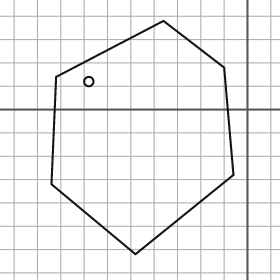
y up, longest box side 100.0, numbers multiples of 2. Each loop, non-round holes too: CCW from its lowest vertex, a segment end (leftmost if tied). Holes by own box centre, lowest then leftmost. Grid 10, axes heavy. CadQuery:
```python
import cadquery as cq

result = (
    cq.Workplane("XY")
    .moveTo(-48.0, -62.0)
    .lineTo(-6.0, -28.0)
    .lineTo(-10.0, 18.0)
    .lineTo(-36.0, 38.0)
    .lineTo(-82.0, 14.0)
    .lineTo(-84.0, -32.0)
    .close()
    .moveTo(-68.0, 12.0)
    .circle(2.0)
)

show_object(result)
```